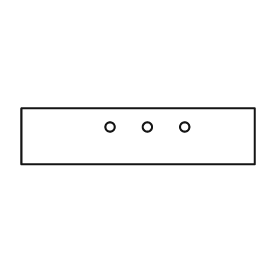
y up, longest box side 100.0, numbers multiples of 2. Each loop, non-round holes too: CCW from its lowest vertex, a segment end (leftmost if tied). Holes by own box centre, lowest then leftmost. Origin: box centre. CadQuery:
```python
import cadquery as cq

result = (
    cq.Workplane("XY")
    .moveTo(-50.0, -12.0)
    .lineTo(50.0, -12.0)
    .lineTo(50.0, 12.0)
    .lineTo(-50.0, 12.0)
    .close()
    .moveTo(-12.0, 4.0)
    .circle(2.0)
    .moveTo(4.0, 4.0)
    .circle(2.0)
    .moveTo(20.0, 4.0)
    .circle(2.0)
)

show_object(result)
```